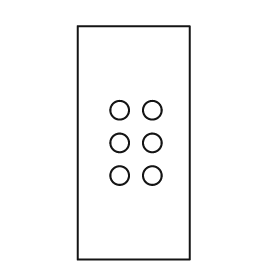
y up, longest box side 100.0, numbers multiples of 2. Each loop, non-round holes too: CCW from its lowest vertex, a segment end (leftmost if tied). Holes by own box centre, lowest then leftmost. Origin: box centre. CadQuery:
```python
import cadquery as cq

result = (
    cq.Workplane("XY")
    .moveTo(-24.0, -50.0)
    .lineTo(24.0, -50.0)
    .lineTo(24.0, 50.0)
    .lineTo(-24.0, 50.0)
    .close()
    .moveTo(-6.0, -14.0)
    .circle(4.0)
    .moveTo(8.0, -14.0)
    .circle(4.0)
    .moveTo(-6.0, 0.0)
    .circle(4.0)
    .moveTo(8.0, 0.0)
    .circle(4.0)
    .moveTo(-6.0, 14.0)
    .circle(4.0)
    .moveTo(8.0, 14.0)
    .circle(4.0)
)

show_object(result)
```